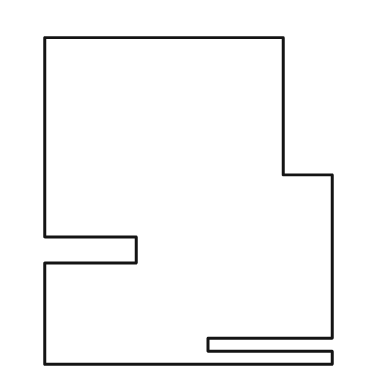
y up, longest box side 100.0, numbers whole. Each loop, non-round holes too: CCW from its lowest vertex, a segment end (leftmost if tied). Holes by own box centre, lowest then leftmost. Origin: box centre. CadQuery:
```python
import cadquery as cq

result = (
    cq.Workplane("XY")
    .moveTo(-44.0, -50.0)
    .lineTo(44.0, -50.0)
    .lineTo(44.0, -46.0)
    .lineTo(6.0, -46.0)
    .lineTo(6.0, -42.0)
    .lineTo(44.0, -42.0)
    .lineTo(44.0, 8.0)
    .lineTo(29.0, 8.0)
    .lineTo(29.0, 50.0)
    .lineTo(-44.0, 50.0)
    .lineTo(-44.0, -11.0)
    .lineTo(-16.0, -11.0)
    .lineTo(-16.0, -19.0)
    .lineTo(-44.0, -19.0)
    .close()
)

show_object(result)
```